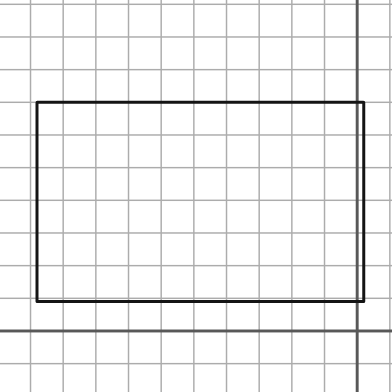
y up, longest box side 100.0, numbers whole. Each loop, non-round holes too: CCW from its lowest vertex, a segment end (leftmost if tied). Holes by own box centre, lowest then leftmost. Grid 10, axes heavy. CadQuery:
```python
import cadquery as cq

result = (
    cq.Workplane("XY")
    .moveTo(-98.0, 9.0)
    .lineTo(2.0, 9.0)
    .lineTo(2.0, 70.0)
    .lineTo(-98.0, 70.0)
    .close()
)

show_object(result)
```